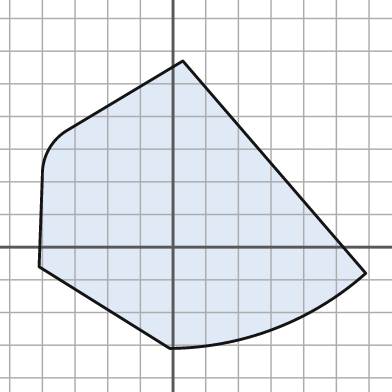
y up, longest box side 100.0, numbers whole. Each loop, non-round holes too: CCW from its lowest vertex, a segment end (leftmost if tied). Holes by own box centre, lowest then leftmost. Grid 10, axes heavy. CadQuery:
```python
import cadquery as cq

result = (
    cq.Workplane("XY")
    .moveTo(-1.0, -31.0)
    .threePointArc((31.0, -25.0), (59.0, -8.0))
    .lineTo(3.0, 57.0)
    .lineTo(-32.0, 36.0)
    .threePointArc((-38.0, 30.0), (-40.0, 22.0))
    .lineTo(-41.0, -6.0)
    .close()
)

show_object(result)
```